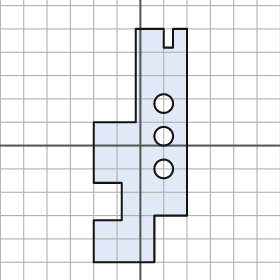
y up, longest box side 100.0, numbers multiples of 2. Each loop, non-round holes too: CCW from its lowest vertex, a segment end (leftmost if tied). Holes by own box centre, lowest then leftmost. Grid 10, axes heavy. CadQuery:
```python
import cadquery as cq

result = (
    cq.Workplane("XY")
    .moveTo(-20.0, -50.0)
    .lineTo(6.0, -50.0)
    .lineTo(6.0, -30.0)
    .lineTo(20.0, -30.0)
    .lineTo(20.0, 50.0)
    .lineTo(14.0, 50.0)
    .lineTo(14.0, 42.0)
    .lineTo(10.0, 42.0)
    .lineTo(10.0, 50.0)
    .lineTo(-2.0, 50.0)
    .lineTo(-2.0, 10.0)
    .lineTo(-20.0, 10.0)
    .lineTo(-20.0, -16.0)
    .lineTo(-8.0, -16.0)
    .lineTo(-8.0, -32.0)
    .lineTo(-20.0, -32.0)
    .close()
    .moveTo(10.0, -10.0)
    .circle(4.0)
    .moveTo(10.0, 4.0)
    .circle(4.0)
    .moveTo(10.0, 18.0)
    .circle(4.0)
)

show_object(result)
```